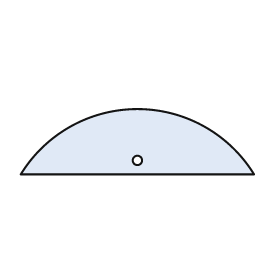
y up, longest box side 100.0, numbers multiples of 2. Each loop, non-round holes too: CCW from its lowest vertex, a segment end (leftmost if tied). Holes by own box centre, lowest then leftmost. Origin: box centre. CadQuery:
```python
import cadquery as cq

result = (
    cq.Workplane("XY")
    .moveTo(-50.0, -14.0)
    .lineTo(50.0, -14.0)
    .threePointArc((0.0, 14.0), (-50.0, -14.0))
    .close()
    .moveTo(0.0, -8.0)
    .circle(2.0)
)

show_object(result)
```